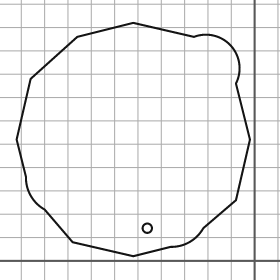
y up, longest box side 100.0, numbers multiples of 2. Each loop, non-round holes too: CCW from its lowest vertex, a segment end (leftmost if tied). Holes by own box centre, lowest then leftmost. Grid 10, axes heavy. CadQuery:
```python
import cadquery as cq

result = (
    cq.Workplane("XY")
    .moveTo(-52.0, 2.0)
    .lineTo(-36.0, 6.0)
    .threePointArc((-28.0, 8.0), (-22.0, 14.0))
    .lineTo(-8.0, 26.0)
    .lineTo(-2.0, 52.0)
    .lineTo(-8.0, 76.0)
    .threePointArc((-10.0, 92.0), (-26.0, 96.0))
    .lineTo(-52.0, 102.0)
    .lineTo(-76.0, 96.0)
    .lineTo(-96.0, 78.0)
    .lineTo(-102.0, 52.0)
    .lineTo(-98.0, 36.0)
    .threePointArc((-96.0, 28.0), (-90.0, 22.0))
    .lineTo(-78.0, 8.0)
    .close()
    .moveTo(-46.0, 14.0)
    .circle(2.0)
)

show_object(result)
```